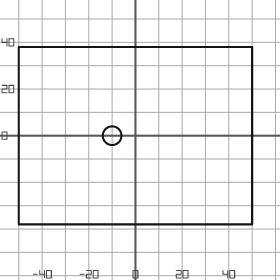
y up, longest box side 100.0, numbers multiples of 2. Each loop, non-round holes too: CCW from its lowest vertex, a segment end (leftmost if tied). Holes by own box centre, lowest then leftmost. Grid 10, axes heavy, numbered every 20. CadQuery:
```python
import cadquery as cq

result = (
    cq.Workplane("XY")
    .moveTo(-50.0, -38.0)
    .lineTo(50.0, -38.0)
    .lineTo(50.0, 38.0)
    .lineTo(-50.0, 38.0)
    .close()
    .moveTo(-10.0, 0.0)
    .circle(4.0)
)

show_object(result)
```